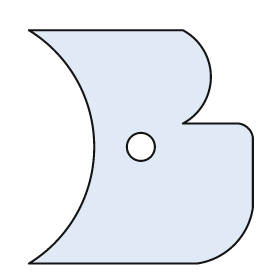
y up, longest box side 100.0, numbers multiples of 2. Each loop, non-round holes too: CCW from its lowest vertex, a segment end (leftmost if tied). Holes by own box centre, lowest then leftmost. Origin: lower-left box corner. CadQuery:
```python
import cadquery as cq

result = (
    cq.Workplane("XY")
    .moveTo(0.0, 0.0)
    .lineTo(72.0, 0.0)
    .threePointArc((88.0, 8.0), (96.0, 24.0))
    .lineTo(96.0, 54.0)
    .threePointArc((94.0, 58.0), (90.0, 60.0))
    .lineTo(66.0, 60.0)
    .threePointArc((78.0, 80.0), (66.0, 100.0))
    .lineTo(0.0, 100.0)
    .threePointArc((28.0, 50.0), (0.0, 0.0))
    .close()
    .moveTo(48.0, 50.0)
    .circle(6.0)
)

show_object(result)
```